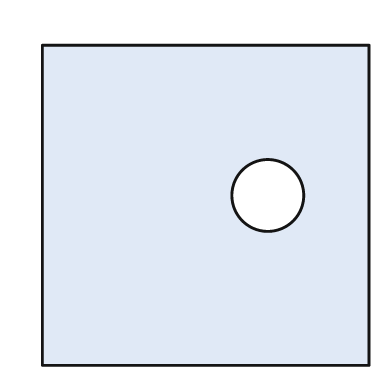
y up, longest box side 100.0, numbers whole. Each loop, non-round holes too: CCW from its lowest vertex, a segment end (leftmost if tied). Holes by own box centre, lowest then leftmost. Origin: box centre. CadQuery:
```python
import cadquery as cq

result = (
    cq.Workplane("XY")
    .moveTo(-50.0, -49.0)
    .lineTo(50.0, -49.0)
    .lineTo(50.0, 49.0)
    .lineTo(-50.0, 49.0)
    .close()
    .moveTo(19.0, 3.0)
    .circle(11.0)
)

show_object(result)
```